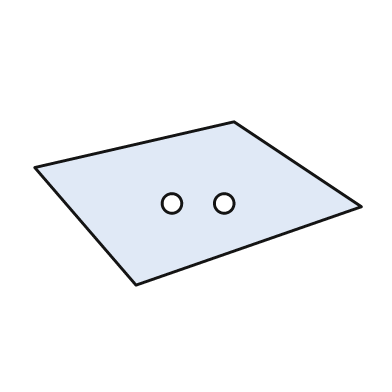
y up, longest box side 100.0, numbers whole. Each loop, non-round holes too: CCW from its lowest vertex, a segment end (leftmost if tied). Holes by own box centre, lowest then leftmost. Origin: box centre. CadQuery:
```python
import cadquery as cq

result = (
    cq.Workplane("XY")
    .moveTo(-19.0, -25.0)
    .lineTo(50.0, -1.0)
    .lineTo(11.0, 25.0)
    .lineTo(-50.0, 11.0)
    .close()
    .moveTo(-8.0, 0.0)
    .circle(3.0)
    .moveTo(8.0, 0.0)
    .circle(3.0)
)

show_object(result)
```